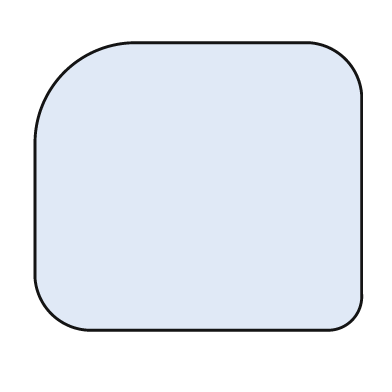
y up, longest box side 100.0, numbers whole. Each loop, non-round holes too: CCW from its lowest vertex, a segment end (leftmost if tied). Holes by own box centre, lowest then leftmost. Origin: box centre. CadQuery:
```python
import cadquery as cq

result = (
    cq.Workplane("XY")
    .moveTo(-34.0, -44.0)
    .lineTo(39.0, -44.0)
    .threePointArc((47.0, -41.0), (50.0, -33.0))
    .lineTo(50.0, 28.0)
    .threePointArc((45.0, 39.0), (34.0, 44.0))
    .lineTo(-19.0, 44.0)
    .threePointArc((-41.0, 35.0), (-50.0, 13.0))
    .lineTo(-50.0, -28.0)
    .threePointArc((-45.0, -39.0), (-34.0, -44.0))
    .close()
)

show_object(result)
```